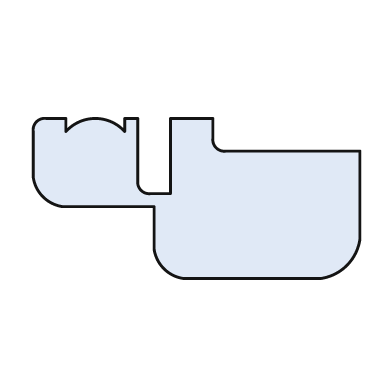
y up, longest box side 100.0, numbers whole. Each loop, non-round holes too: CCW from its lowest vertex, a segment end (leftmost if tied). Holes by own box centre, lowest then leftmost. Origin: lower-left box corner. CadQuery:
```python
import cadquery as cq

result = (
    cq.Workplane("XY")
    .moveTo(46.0, 0.0)
    .lineTo(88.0, 0.0)
    .threePointArc((96.0, 4.0), (100.0, 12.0))
    .lineTo(100.0, 39.0)
    .lineTo(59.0, 39.0)
    .threePointArc((56.0, 40.0), (55.0, 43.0))
    .lineTo(55.0, 49.0)
    .lineTo(42.0, 49.0)
    .lineTo(42.0, 26.0)
    .lineTo(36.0, 26.0)
    .threePointArc((33.0, 27.0), (32.0, 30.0))
    .lineTo(32.0, 49.0)
    .lineTo(28.0, 49.0)
    .lineTo(28.0, 45.0)
    .threePointArc((19.0, 49.0), (10.0, 45.0))
    .lineTo(10.0, 49.0)
    .lineTo(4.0, 49.0)
    .threePointArc((1.0, 48.0), (0.0, 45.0))
    .lineTo(0.0, 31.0)
    .threePointArc((3.0, 25.0), (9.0, 22.0))
    .lineTo(37.0, 22.0)
    .lineTo(37.0, 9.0)
    .threePointArc((40.0, 3.0), (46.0, 0.0))
    .close()
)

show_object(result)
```